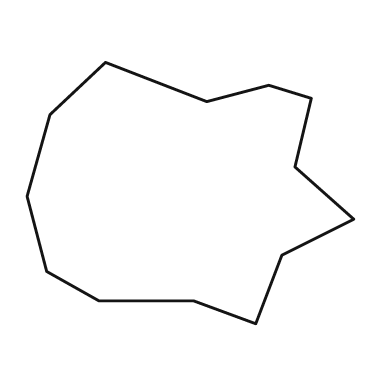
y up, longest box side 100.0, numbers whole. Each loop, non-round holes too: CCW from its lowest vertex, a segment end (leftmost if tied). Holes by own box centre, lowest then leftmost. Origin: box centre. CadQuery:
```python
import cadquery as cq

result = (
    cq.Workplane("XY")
    .moveTo(20.0, -40.0)
    .lineTo(28.0, -19.0)
    .lineTo(50.0, -8.0)
    .lineTo(32.0, 8.0)
    .lineTo(37.0, 29.0)
    .lineTo(24.0, 33.0)
    .lineTo(5.0, 28.0)
    .lineTo(-26.0, 40.0)
    .lineTo(-43.0, 24.0)
    .lineTo(-50.0, -1.0)
    .lineTo(-44.0, -24.0)
    .lineTo(-28.0, -33.0)
    .lineTo(1.0, -33.0)
    .close()
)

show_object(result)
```